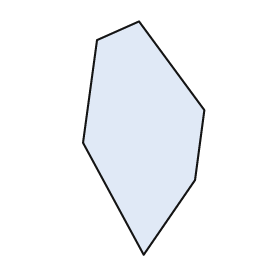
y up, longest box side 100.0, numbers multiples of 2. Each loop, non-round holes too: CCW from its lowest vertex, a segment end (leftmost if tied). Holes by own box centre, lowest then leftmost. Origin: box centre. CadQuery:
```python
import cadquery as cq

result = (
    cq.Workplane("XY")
    .moveTo(0.0, -50.0)
    .lineTo(22.0, -18.0)
    .lineTo(26.0, 12.0)
    .lineTo(-2.0, 50.0)
    .lineTo(-20.0, 42.0)
    .lineTo(-26.0, -2.0)
    .close()
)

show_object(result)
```